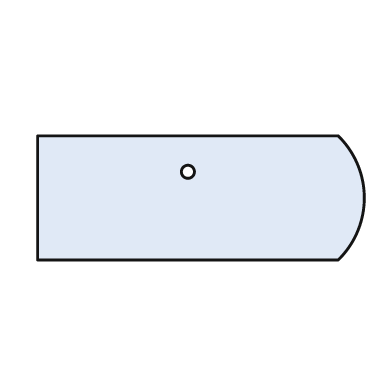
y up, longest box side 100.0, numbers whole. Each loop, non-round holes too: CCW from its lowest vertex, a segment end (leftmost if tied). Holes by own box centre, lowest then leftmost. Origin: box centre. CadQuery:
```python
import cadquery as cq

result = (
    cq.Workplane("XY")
    .moveTo(-50.0, -19.0)
    .lineTo(42.0, -19.0)
    .threePointArc((50.0, 0.0), (42.0, 19.0))
    .lineTo(-50.0, 19.0)
    .close()
    .moveTo(-4.0, 8.0)
    .circle(2.0)
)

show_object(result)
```